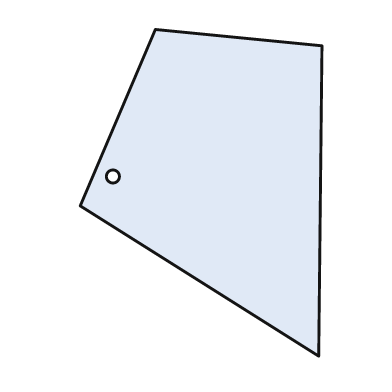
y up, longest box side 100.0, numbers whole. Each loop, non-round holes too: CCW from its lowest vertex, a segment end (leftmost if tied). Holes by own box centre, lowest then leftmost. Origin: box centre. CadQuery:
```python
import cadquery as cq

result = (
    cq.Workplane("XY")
    .moveTo(36.0, -50.0)
    .lineTo(37.0, 45.0)
    .lineTo(-14.0, 50.0)
    .lineTo(-37.0, -4.0)
    .close()
    .moveTo(-27.0, 5.0)
    .circle(2.0)
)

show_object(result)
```